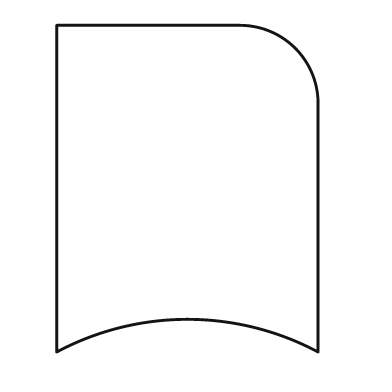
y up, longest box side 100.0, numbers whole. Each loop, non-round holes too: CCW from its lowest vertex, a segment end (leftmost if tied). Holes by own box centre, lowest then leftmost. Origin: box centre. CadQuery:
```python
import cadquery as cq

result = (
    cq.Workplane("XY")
    .moveTo(-40.0, -50.0)
    .threePointArc((0.0, -40.0), (40.0, -50.0))
    .lineTo(40.0, 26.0)
    .threePointArc((33.0, 43.0), (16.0, 50.0))
    .lineTo(-40.0, 50.0)
    .close()
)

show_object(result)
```